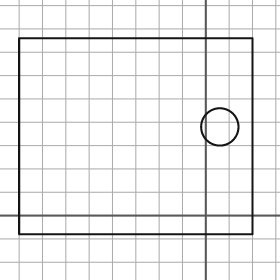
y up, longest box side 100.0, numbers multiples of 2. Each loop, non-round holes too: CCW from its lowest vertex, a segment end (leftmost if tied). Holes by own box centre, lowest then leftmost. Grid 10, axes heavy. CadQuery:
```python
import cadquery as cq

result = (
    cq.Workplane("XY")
    .moveTo(-80.0, -8.0)
    .lineTo(20.0, -8.0)
    .lineTo(20.0, 76.0)
    .lineTo(-80.0, 76.0)
    .close()
    .moveTo(6.0, 38.0)
    .circle(8.0)
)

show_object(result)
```